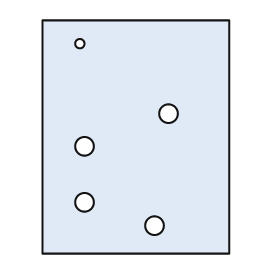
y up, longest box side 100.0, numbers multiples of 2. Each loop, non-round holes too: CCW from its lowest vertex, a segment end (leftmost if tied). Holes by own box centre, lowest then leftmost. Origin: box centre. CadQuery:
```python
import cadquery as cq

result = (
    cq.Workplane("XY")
    .moveTo(-40.0, -50.0)
    .lineTo(40.0, -50.0)
    .lineTo(40.0, 50.0)
    .lineTo(-40.0, 50.0)
    .close()
    .moveTo(8.0, -38.0)
    .circle(4.0)
    .moveTo(-22.0, -28.0)
    .circle(4.0)
    .moveTo(-22.0, -4.0)
    .circle(4.0)
    .moveTo(14.0, 10.0)
    .circle(4.0)
    .moveTo(-24.0, 40.0)
    .circle(2.0)
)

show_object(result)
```